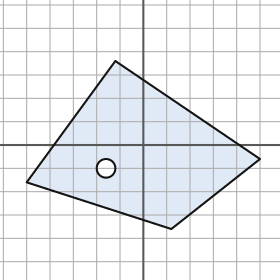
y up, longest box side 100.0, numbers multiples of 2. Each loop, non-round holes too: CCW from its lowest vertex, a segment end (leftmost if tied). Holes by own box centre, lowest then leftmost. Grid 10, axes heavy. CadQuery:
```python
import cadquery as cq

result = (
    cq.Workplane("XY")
    .moveTo(12.0, -36.0)
    .lineTo(50.0, -6.0)
    .lineTo(-12.0, 36.0)
    .lineTo(-50.0, -16.0)
    .close()
    .moveTo(-16.0, -10.0)
    .circle(4.0)
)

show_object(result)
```